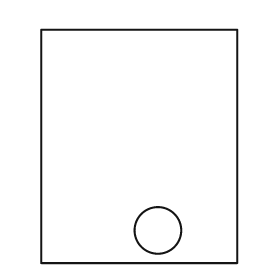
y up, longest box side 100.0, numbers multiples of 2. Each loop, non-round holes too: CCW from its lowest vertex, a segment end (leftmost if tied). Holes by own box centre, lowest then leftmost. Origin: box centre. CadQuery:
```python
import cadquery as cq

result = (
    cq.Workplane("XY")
    .moveTo(-42.0, -50.0)
    .lineTo(42.0, -50.0)
    .lineTo(42.0, 50.0)
    .lineTo(-42.0, 50.0)
    .close()
    .moveTo(8.0, -36.0)
    .circle(10.0)
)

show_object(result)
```